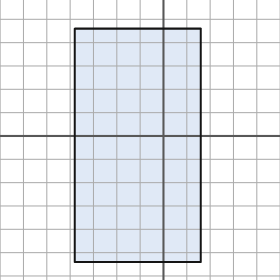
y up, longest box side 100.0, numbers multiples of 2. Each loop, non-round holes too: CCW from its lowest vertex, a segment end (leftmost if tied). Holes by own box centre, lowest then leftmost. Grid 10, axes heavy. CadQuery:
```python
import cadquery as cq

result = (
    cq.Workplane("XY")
    .moveTo(-38.0, -54.0)
    .lineTo(16.0, -54.0)
    .lineTo(16.0, 46.0)
    .lineTo(-38.0, 46.0)
    .close()
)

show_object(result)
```